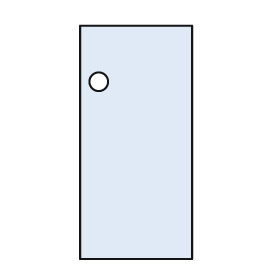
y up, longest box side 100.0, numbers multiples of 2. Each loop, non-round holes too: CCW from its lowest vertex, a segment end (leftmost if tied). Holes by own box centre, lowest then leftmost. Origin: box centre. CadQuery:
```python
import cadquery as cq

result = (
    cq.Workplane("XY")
    .moveTo(-24.0, -50.0)
    .lineTo(24.0, -50.0)
    .lineTo(24.0, 50.0)
    .lineTo(-24.0, 50.0)
    .close()
    .moveTo(-16.0, 26.0)
    .circle(4.0)
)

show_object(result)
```